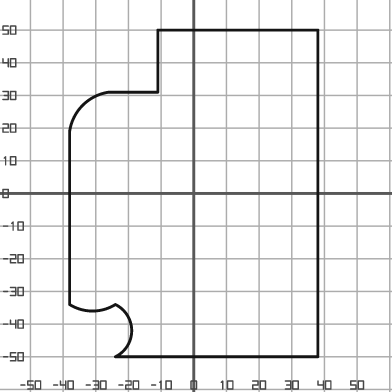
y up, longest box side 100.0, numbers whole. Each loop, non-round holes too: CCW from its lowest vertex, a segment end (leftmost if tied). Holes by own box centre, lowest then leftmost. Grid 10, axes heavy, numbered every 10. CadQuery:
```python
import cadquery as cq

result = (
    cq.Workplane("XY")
    .moveTo(-24.0, -50.0)
    .lineTo(38.0, -50.0)
    .lineTo(38.0, 50.0)
    .lineTo(-11.0, 50.0)
    .lineTo(-11.0, 31.0)
    .lineTo(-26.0, 31.0)
    .threePointArc((-34.0, 27.0), (-38.0, 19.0))
    .lineTo(-38.0, -34.0)
    .threePointArc((-31.0, -36.0), (-24.0, -34.0))
    .threePointArc((-19.0, -42.0), (-24.0, -50.0))
    .close()
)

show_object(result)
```